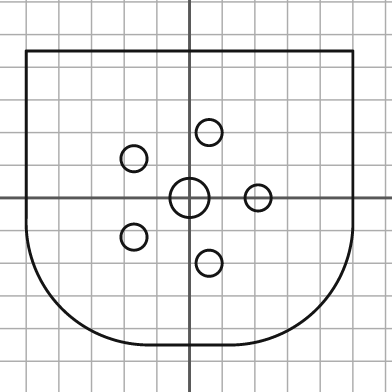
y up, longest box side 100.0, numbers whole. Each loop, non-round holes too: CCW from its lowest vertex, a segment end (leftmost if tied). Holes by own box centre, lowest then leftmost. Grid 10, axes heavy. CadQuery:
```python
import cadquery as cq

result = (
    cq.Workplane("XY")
    .moveTo(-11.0, -45.0)
    .lineTo(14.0, -45.0)
    .threePointArc((39.0, -34.0), (50.0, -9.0))
    .lineTo(50.0, 45.0)
    .lineTo(-50.0, 45.0)
    .lineTo(-50.0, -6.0)
    .threePointArc((-39.0, -34.0), (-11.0, -45.0))
    .close()
    .moveTo(6.0, -20.0)
    .circle(4.0)
    .moveTo(-17.0, -12.0)
    .circle(4.0)
    .moveTo(0.0, 0.0)
    .circle(6.0)
    .moveTo(21.0, 0.0)
    .circle(4.0)
    .moveTo(-17.0, 12.0)
    .circle(4.0)
    .moveTo(6.0, 20.0)
    .circle(4.0)
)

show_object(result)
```